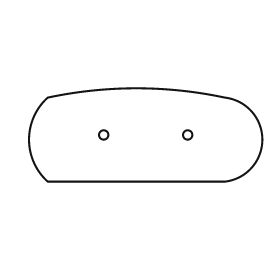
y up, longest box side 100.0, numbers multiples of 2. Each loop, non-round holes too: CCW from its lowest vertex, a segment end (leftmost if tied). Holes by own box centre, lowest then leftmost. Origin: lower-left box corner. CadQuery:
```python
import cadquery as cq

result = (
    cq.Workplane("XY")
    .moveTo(8.0, 0.0)
    .lineTo(84.0, 0.0)
    .threePointArc((100.0, 18.0), (84.0, 36.0))
    .threePointArc((46.0, 40.0), (8.0, 36.0))
    .threePointArc((0.0, 18.0), (8.0, 0.0))
    .close()
    .moveTo(32.0, 20.0)
    .circle(2.0)
    .moveTo(68.0, 20.0)
    .circle(2.0)
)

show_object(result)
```